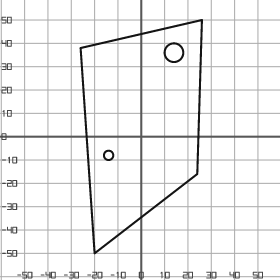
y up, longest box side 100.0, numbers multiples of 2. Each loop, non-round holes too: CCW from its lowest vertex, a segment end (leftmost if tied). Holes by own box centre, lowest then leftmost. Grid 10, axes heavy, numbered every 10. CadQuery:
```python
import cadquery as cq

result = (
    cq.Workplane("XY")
    .moveTo(-20.0, -50.0)
    .lineTo(24.0, -16.0)
    .lineTo(26.0, 50.0)
    .lineTo(-26.0, 38.0)
    .close()
    .moveTo(-14.0, -8.0)
    .circle(2.0)
    .moveTo(14.0, 36.0)
    .circle(4.0)
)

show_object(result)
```